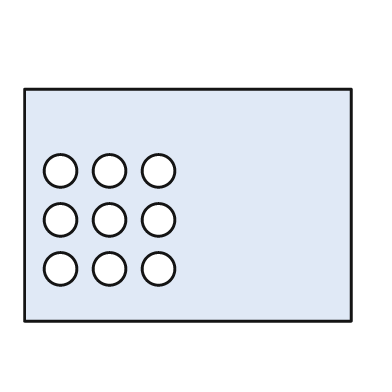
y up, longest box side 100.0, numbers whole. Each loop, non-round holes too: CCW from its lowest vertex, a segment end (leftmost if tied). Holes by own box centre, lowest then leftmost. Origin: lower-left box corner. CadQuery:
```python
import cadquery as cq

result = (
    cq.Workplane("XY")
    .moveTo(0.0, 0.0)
    .lineTo(100.0, 0.0)
    .lineTo(100.0, 71.0)
    .lineTo(0.0, 71.0)
    .close()
    .moveTo(11.0, 16.0)
    .circle(5.0)
    .moveTo(26.0, 16.0)
    .circle(5.0)
    .moveTo(41.0, 16.0)
    .circle(5.0)
    .moveTo(11.0, 31.0)
    .circle(5.0)
    .moveTo(26.0, 31.0)
    .circle(5.0)
    .moveTo(41.0, 31.0)
    .circle(5.0)
    .moveTo(11.0, 46.0)
    .circle(5.0)
    .moveTo(26.0, 46.0)
    .circle(5.0)
    .moveTo(41.0, 46.0)
    .circle(5.0)
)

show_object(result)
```